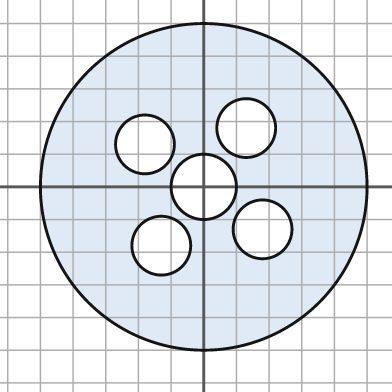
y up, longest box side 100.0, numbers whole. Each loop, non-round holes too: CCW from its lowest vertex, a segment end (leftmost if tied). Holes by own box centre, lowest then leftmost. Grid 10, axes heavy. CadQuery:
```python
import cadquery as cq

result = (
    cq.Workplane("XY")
    .moveTo(0.0, 0.0)
    .circle(50.0)
    .moveTo(-13.0, -18.0)
    .circle(9.0)
    .moveTo(18.0, -13.0)
    .circle(9.0)
    .moveTo(0.0, 0.0)
    .circle(10.0)
    .moveTo(-18.0, 13.0)
    .circle(9.0)
    .moveTo(13.0, 18.0)
    .circle(9.0)
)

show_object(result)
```